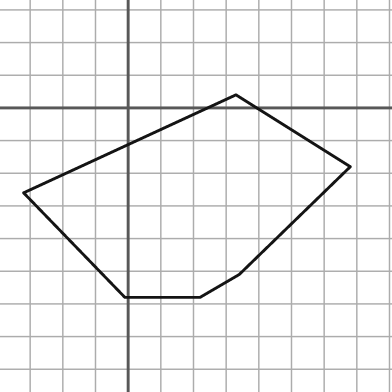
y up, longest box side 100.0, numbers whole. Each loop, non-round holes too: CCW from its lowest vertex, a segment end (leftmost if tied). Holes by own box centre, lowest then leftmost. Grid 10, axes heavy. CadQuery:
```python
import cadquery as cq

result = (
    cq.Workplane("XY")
    .moveTo(-1.0, -58.0)
    .lineTo(22.0, -58.0)
    .lineTo(34.0, -51.0)
    .lineTo(68.0, -18.0)
    .lineTo(33.0, 4.0)
    .lineTo(-32.0, -26.0)
    .close()
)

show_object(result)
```